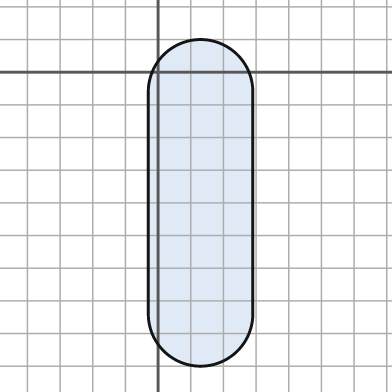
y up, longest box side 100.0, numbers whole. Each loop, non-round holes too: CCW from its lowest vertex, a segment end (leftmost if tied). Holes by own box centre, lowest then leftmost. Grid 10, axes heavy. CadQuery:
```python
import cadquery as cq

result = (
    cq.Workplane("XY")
    .moveTo(-3.0, -74.0)
    .threePointArc((13.0, -90.0), (29.0, -74.0))
    .lineTo(29.0, -6.0)
    .threePointArc((13.0, 10.0), (-3.0, -6.0))
    .close()
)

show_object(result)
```